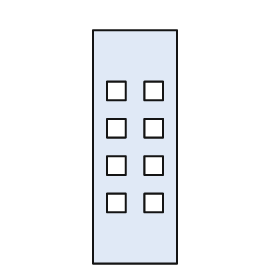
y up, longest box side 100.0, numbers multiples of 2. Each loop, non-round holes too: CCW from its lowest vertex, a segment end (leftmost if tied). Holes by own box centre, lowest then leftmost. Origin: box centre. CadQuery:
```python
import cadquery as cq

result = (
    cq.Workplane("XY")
    .moveTo(-18.0, -50.0)
    .lineTo(18.0, -50.0)
    .lineTo(18.0, 50.0)
    .lineTo(-18.0, 50.0)
    .close()
    .moveTo(-12.0, -28.0)
    .lineTo(-4.0, -28.0)
    .lineTo(-4.0, -20.0)
    .lineTo(-12.0, -20.0)
    .close()
    .moveTo(4.0, -28.0)
    .lineTo(12.0, -28.0)
    .lineTo(12.0, -20.0)
    .lineTo(4.0, -20.0)
    .close()
    .moveTo(-12.0, -12.0)
    .lineTo(-4.0, -12.0)
    .lineTo(-4.0, -4.0)
    .lineTo(-12.0, -4.0)
    .close()
    .moveTo(4.0, -12.0)
    .lineTo(12.0, -12.0)
    .lineTo(12.0, -4.0)
    .lineTo(4.0, -4.0)
    .close()
    .moveTo(-12.0, 4.0)
    .lineTo(-4.0, 4.0)
    .lineTo(-4.0, 12.0)
    .lineTo(-12.0, 12.0)
    .close()
    .moveTo(4.0, 4.0)
    .lineTo(12.0, 4.0)
    .lineTo(12.0, 12.0)
    .lineTo(4.0, 12.0)
    .close()
    .moveTo(-12.0, 20.0)
    .lineTo(-4.0, 20.0)
    .lineTo(-4.0, 28.0)
    .lineTo(-12.0, 28.0)
    .close()
    .moveTo(4.0, 20.0)
    .lineTo(12.0, 20.0)
    .lineTo(12.0, 28.0)
    .lineTo(4.0, 28.0)
    .close()
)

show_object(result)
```